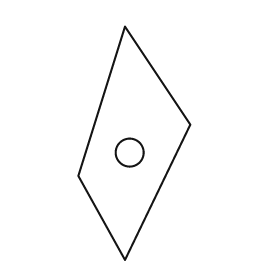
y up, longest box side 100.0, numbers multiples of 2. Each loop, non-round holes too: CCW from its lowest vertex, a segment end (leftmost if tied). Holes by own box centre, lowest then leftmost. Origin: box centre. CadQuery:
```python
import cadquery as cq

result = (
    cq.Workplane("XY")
    .moveTo(-4.0, -50.0)
    .lineTo(24.0, 8.0)
    .lineTo(-4.0, 50.0)
    .lineTo(-24.0, -14.0)
    .close()
    .moveTo(-2.0, -4.0)
    .circle(6.0)
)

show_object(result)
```